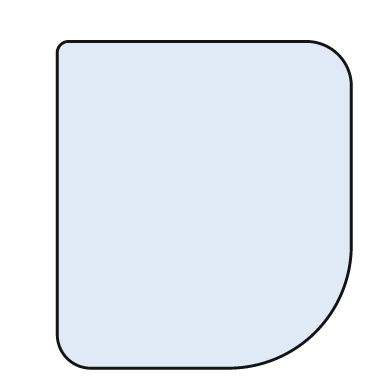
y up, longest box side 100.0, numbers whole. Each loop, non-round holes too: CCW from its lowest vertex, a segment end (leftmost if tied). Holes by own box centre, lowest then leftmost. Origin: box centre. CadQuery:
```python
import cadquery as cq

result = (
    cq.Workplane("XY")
    .moveTo(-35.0, -50.0)
    .lineTo(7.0, -50.0)
    .threePointArc((34.0, -39.0), (45.0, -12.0))
    .lineTo(45.0, 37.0)
    .threePointArc((41.0, 46.0), (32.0, 50.0))
    .lineTo(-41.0, 50.0)
    .threePointArc((-44.0, 49.0), (-45.0, 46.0))
    .lineTo(-45.0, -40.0)
    .threePointArc((-42.0, -47.0), (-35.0, -50.0))
    .close()
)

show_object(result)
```